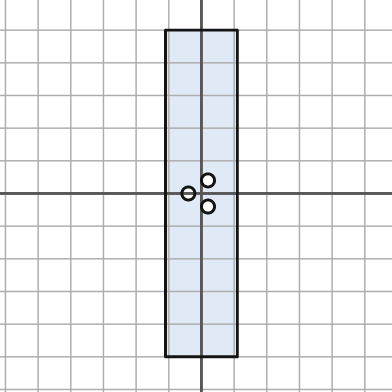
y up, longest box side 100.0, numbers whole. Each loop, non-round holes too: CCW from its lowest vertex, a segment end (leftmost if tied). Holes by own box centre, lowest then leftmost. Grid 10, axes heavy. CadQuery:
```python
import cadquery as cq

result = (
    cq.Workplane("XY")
    .moveTo(-11.0, -50.0)
    .lineTo(11.0, -50.0)
    .lineTo(11.0, 50.0)
    .lineTo(-11.0, 50.0)
    .close()
    .moveTo(2.0, -4.0)
    .circle(2.0)
    .moveTo(-4.0, 0.0)
    .circle(2.0)
    .moveTo(2.0, 4.0)
    .circle(2.0)
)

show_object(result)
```